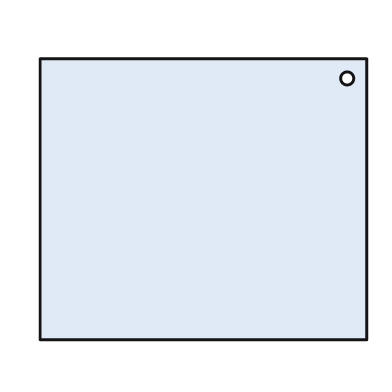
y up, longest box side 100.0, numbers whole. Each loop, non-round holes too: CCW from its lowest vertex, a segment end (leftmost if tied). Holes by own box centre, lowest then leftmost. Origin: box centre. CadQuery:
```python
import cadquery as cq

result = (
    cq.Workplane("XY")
    .moveTo(-50.0, -43.0)
    .lineTo(50.0, -43.0)
    .lineTo(50.0, 43.0)
    .lineTo(-50.0, 43.0)
    .close()
    .moveTo(44.0, 37.0)
    .circle(2.0)
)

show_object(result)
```